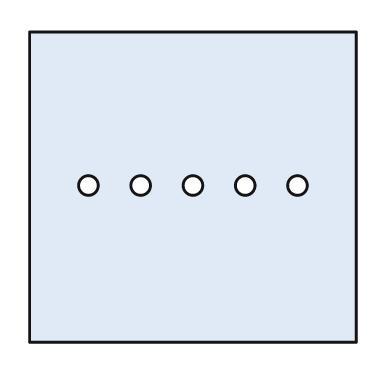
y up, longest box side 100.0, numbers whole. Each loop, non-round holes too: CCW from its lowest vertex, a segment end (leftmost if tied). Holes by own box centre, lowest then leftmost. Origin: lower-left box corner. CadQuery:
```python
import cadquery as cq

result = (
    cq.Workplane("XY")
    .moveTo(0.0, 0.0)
    .lineTo(100.0, 0.0)
    .lineTo(100.0, 95.0)
    .lineTo(0.0, 95.0)
    .close()
    .moveTo(18.0, 48.0)
    .circle(3.0)
    .moveTo(34.0, 48.0)
    .circle(3.0)
    .moveTo(50.0, 48.0)
    .circle(3.0)
    .moveTo(66.0, 48.0)
    .circle(3.0)
    .moveTo(82.0, 48.0)
    .circle(3.0)
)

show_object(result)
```